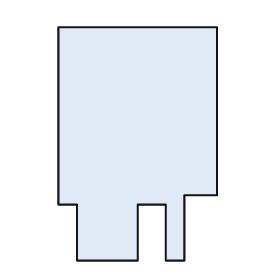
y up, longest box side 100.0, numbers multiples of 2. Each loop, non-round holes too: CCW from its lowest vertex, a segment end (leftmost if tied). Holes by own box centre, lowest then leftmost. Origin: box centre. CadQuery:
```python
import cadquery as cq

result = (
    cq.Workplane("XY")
    .moveTo(-26.0, -50.0)
    .lineTo(0.0, -50.0)
    .lineTo(0.0, -26.0)
    .lineTo(12.0, -26.0)
    .lineTo(12.0, -50.0)
    .lineTo(20.0, -50.0)
    .lineTo(20.0, -22.0)
    .lineTo(34.0, -22.0)
    .lineTo(34.0, 50.0)
    .lineTo(-34.0, 50.0)
    .lineTo(-34.0, -26.0)
    .lineTo(-26.0, -26.0)
    .close()
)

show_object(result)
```